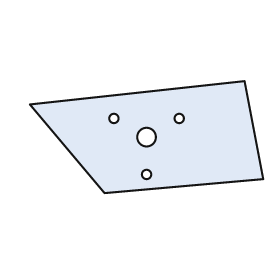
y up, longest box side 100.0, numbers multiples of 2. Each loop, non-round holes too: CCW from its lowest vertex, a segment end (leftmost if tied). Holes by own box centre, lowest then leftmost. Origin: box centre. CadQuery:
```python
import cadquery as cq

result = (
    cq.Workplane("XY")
    .moveTo(-18.0, -24.0)
    .lineTo(50.0, -18.0)
    .lineTo(42.0, 24.0)
    .lineTo(-50.0, 14.0)
    .close()
    .moveTo(0.0, -16.0)
    .circle(2.0)
    .moveTo(0.0, 0.0)
    .circle(4.0)
    .moveTo(-14.0, 8.0)
    .circle(2.0)
    .moveTo(14.0, 8.0)
    .circle(2.0)
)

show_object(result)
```